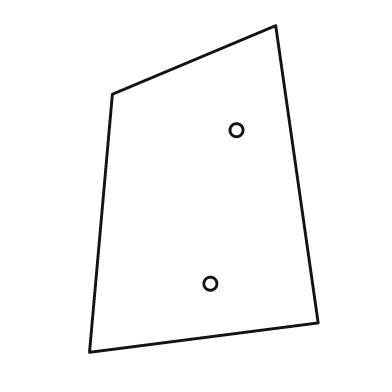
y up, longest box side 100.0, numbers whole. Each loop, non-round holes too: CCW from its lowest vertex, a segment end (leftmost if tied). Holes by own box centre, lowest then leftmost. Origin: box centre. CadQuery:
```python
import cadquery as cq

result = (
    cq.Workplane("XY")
    .moveTo(-35.0, -50.0)
    .lineTo(35.0, -41.0)
    .lineTo(22.0, 50.0)
    .lineTo(-28.0, 29.0)
    .close()
    .moveTo(2.0, -29.0)
    .circle(2.0)
    .moveTo(10.0, 18.0)
    .circle(2.0)
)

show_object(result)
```